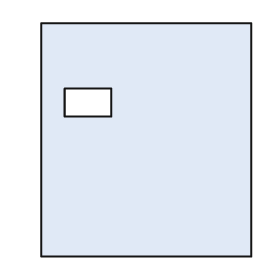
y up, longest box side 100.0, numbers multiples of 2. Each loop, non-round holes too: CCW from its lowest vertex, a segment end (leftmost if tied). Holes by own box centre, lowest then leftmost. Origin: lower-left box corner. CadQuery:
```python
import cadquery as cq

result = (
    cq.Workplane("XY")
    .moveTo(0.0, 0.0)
    .lineTo(90.0, 0.0)
    .lineTo(90.0, 100.0)
    .lineTo(0.0, 100.0)
    .close()
    .moveTo(10.0, 60.0)
    .lineTo(30.0, 60.0)
    .lineTo(30.0, 72.0)
    .lineTo(10.0, 72.0)
    .close()
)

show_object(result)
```